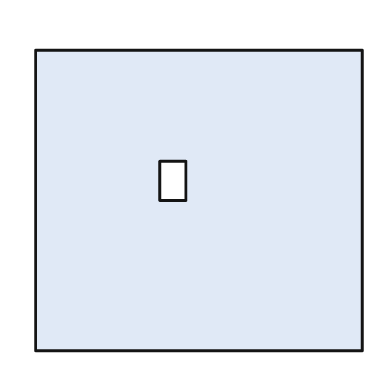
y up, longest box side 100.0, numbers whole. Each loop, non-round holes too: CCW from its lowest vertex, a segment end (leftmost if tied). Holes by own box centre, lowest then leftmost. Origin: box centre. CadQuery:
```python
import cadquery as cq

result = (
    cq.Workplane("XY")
    .moveTo(-50.0, -46.0)
    .lineTo(50.0, -46.0)
    .lineTo(50.0, 46.0)
    .lineTo(-50.0, 46.0)
    .close()
    .moveTo(-12.0, 0.0)
    .lineTo(-4.0, 0.0)
    .lineTo(-4.0, 12.0)
    .lineTo(-12.0, 12.0)
    .close()
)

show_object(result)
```